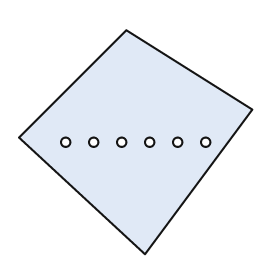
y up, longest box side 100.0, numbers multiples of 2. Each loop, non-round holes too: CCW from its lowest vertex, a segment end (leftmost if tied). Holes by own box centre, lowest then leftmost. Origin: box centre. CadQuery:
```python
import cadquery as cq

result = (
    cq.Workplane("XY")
    .moveTo(4.0, -48.0)
    .lineTo(50.0, 14.0)
    .lineTo(-4.0, 48.0)
    .lineTo(-50.0, 2.0)
    .close()
    .moveTo(-30.0, 0.0)
    .circle(2.0)
    .moveTo(-18.0, 0.0)
    .circle(2.0)
    .moveTo(-6.0, 0.0)
    .circle(2.0)
    .moveTo(6.0, 0.0)
    .circle(2.0)
    .moveTo(18.0, 0.0)
    .circle(2.0)
    .moveTo(30.0, 0.0)
    .circle(2.0)
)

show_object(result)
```